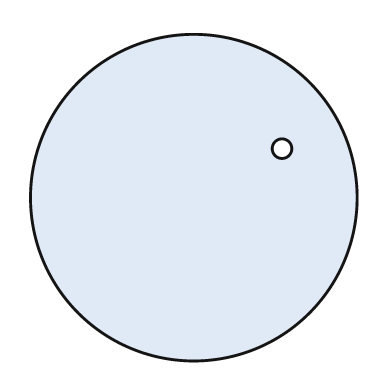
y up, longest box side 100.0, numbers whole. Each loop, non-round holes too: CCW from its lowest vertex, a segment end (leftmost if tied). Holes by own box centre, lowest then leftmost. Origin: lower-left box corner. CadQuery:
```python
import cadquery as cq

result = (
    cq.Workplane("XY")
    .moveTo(50.0, 50.0)
    .circle(50.0)
    .moveTo(77.0, 65.0)
    .circle(3.0)
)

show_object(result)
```